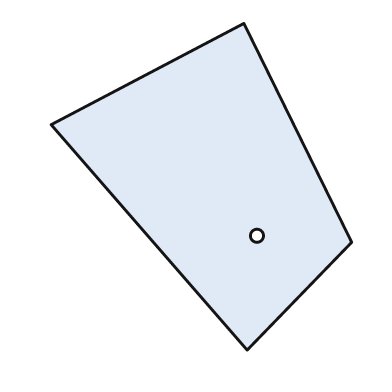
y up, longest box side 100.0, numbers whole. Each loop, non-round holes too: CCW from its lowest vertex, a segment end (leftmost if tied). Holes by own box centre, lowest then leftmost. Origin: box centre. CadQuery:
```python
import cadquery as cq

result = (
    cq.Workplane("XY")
    .moveTo(14.0, -50.0)
    .lineTo(46.0, -17.0)
    .lineTo(13.0, 50.0)
    .lineTo(-46.0, 19.0)
    .close()
    .moveTo(17.0, -15.0)
    .circle(2.0)
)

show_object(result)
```